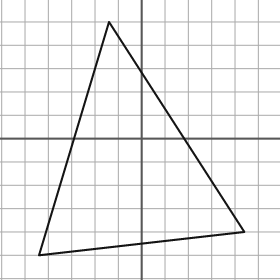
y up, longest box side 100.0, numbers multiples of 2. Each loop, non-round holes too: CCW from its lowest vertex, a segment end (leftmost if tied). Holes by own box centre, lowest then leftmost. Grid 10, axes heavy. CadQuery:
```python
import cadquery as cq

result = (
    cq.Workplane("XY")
    .moveTo(-44.0, -50.0)
    .lineTo(44.0, -40.0)
    .lineTo(-14.0, 50.0)
    .close()
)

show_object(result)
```